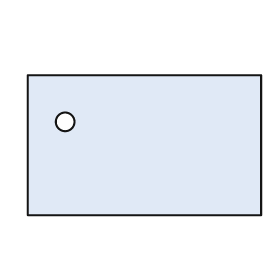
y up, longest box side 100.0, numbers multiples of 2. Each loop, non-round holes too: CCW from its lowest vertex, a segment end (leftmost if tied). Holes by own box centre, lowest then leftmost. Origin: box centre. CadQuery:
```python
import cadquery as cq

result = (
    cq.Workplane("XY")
    .moveTo(-50.0, -30.0)
    .lineTo(50.0, -30.0)
    .lineTo(50.0, 30.0)
    .lineTo(-50.0, 30.0)
    .close()
    .moveTo(-34.0, 10.0)
    .circle(4.0)
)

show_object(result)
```